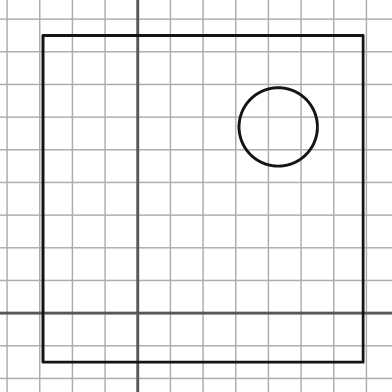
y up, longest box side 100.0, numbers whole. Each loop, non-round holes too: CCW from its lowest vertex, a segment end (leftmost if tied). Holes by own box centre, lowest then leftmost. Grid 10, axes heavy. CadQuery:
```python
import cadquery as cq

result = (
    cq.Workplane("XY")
    .moveTo(-29.0, -15.0)
    .lineTo(69.0, -15.0)
    .lineTo(69.0, 85.0)
    .lineTo(-29.0, 85.0)
    .close()
    .moveTo(43.0, 57.0)
    .circle(12.0)
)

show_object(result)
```